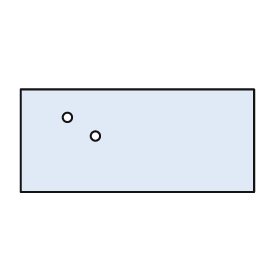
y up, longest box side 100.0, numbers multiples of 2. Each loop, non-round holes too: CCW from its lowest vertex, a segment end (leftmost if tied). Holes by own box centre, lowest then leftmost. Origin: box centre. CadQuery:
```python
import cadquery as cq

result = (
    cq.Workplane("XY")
    .moveTo(-50.0, -22.0)
    .lineTo(50.0, -22.0)
    .lineTo(50.0, 22.0)
    .lineTo(-50.0, 22.0)
    .close()
    .moveTo(-18.0, 2.0)
    .circle(2.0)
    .moveTo(-30.0, 10.0)
    .circle(2.0)
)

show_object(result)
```